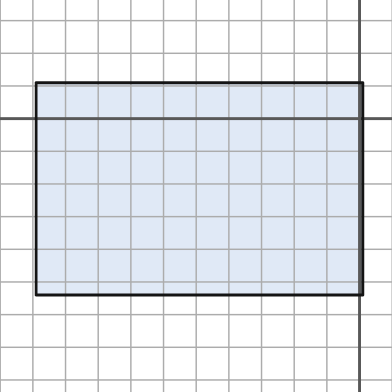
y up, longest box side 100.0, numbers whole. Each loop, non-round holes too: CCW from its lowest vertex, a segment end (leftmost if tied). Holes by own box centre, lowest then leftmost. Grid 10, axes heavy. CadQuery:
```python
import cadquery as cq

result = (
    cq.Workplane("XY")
    .moveTo(-99.0, -54.0)
    .lineTo(1.0, -54.0)
    .lineTo(1.0, 11.0)
    .lineTo(-99.0, 11.0)
    .close()
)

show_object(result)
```